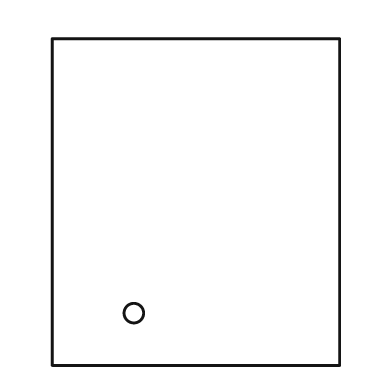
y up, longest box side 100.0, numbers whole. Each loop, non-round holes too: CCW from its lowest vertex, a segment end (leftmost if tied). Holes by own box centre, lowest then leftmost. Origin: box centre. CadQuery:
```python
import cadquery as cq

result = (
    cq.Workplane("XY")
    .moveTo(-44.0, -50.0)
    .lineTo(44.0, -50.0)
    .lineTo(44.0, 50.0)
    .lineTo(-44.0, 50.0)
    .close()
    .moveTo(-19.0, -34.0)
    .circle(3.0)
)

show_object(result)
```